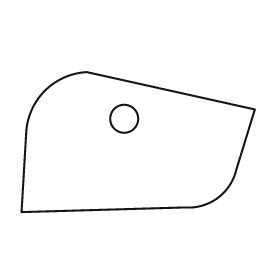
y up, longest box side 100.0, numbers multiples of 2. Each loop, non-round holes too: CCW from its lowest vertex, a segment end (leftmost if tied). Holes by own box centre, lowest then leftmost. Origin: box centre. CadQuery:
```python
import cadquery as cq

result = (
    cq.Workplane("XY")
    .moveTo(-50.0, -30.0)
    .lineTo(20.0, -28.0)
    .threePointArc((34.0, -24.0), (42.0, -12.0))
    .lineTo(50.0, 14.0)
    .lineTo(-22.0, 30.0)
    .threePointArc((-40.0, 22.0), (-48.0, 4.0))
    .close()
    .moveTo(-6.0, 10.0)
    .circle(6.0)
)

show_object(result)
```